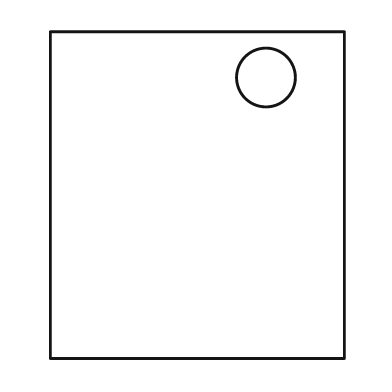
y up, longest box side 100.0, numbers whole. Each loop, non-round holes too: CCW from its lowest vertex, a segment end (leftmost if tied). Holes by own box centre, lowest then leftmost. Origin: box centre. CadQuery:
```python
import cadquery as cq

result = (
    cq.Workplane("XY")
    .moveTo(-45.0, -50.0)
    .lineTo(45.0, -50.0)
    .lineTo(45.0, 50.0)
    .lineTo(-45.0, 50.0)
    .close()
    .moveTo(21.0, 36.0)
    .circle(9.0)
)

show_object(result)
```